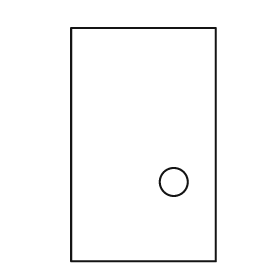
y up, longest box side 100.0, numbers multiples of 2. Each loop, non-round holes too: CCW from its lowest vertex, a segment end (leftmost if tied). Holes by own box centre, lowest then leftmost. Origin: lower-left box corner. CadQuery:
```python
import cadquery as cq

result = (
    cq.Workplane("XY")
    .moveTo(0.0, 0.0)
    .lineTo(62.0, 0.0)
    .lineTo(62.0, 100.0)
    .lineTo(0.0, 100.0)
    .close()
    .moveTo(44.0, 34.0)
    .circle(6.0)
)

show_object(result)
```